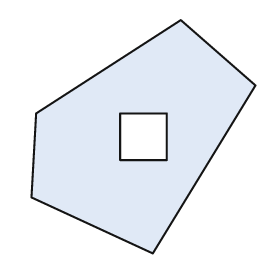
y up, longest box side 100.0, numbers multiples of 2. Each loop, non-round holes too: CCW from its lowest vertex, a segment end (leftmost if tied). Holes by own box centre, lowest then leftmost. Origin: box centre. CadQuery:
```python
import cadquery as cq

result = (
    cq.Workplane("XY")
    .moveTo(4.0, -50.0)
    .lineTo(48.0, 22.0)
    .lineTo(16.0, 50.0)
    .lineTo(-46.0, 10.0)
    .lineTo(-48.0, -26.0)
    .close()
    .moveTo(-10.0, -10.0)
    .lineTo(10.0, -10.0)
    .lineTo(10.0, 10.0)
    .lineTo(-10.0, 10.0)
    .close()
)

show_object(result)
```